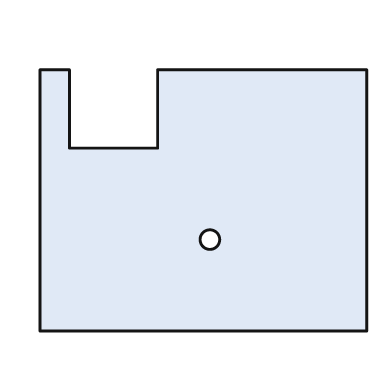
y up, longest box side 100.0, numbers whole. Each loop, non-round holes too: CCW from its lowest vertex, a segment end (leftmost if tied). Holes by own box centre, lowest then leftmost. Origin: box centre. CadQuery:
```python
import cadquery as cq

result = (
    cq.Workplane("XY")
    .moveTo(-50.0, -40.0)
    .lineTo(50.0, -40.0)
    .lineTo(50.0, 40.0)
    .lineTo(-14.0, 40.0)
    .lineTo(-14.0, 16.0)
    .lineTo(-41.0, 16.0)
    .lineTo(-41.0, 40.0)
    .lineTo(-50.0, 40.0)
    .close()
    .moveTo(2.0, -12.0)
    .circle(3.0)
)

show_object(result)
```